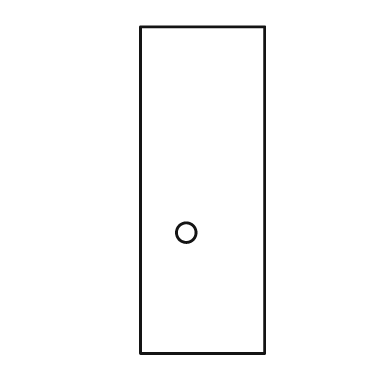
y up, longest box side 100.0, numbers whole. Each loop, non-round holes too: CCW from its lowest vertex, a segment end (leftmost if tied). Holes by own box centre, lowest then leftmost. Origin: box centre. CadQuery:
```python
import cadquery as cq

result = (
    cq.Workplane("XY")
    .moveTo(-19.0, -50.0)
    .lineTo(19.0, -50.0)
    .lineTo(19.0, 50.0)
    .lineTo(-19.0, 50.0)
    .close()
    .moveTo(-5.0, -13.0)
    .circle(3.0)
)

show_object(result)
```